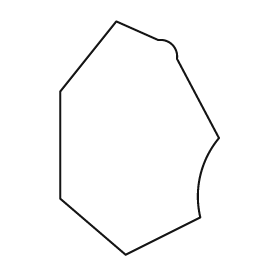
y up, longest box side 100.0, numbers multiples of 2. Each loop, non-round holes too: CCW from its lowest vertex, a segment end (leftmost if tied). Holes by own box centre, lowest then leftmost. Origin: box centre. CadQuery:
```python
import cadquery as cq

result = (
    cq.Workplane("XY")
    .moveTo(-6.0, -50.0)
    .lineTo(26.0, -34.0)
    .threePointArc((26.0, -16.0), (34.0, 0.0))
    .lineTo(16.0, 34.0)
    .threePointArc((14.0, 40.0), (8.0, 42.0))
    .lineTo(-10.0, 50.0)
    .lineTo(-34.0, 20.0)
    .lineTo(-34.0, -26.0)
    .close()
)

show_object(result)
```